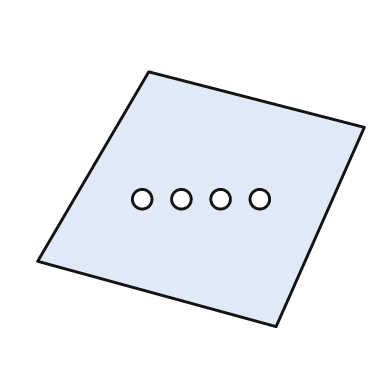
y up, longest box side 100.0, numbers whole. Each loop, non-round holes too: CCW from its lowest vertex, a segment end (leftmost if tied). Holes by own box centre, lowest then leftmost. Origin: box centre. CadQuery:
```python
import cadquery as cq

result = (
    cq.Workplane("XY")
    .moveTo(23.0, -39.0)
    .lineTo(50.0, 22.0)
    .lineTo(-16.0, 39.0)
    .lineTo(-50.0, -19.0)
    .close()
    .moveTo(-18.0, 0.0)
    .circle(3.0)
    .moveTo(-6.0, 0.0)
    .circle(3.0)
    .moveTo(6.0, 0.0)
    .circle(3.0)
    .moveTo(18.0, 0.0)
    .circle(3.0)
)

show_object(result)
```